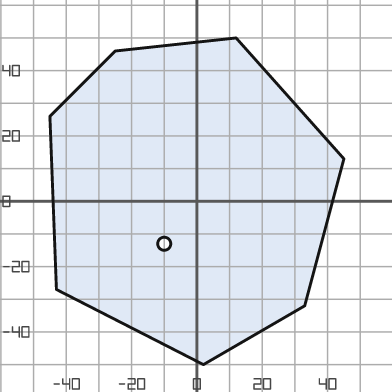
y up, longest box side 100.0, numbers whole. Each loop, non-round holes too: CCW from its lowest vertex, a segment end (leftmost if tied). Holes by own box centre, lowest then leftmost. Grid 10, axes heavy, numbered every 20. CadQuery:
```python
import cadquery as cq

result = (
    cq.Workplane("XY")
    .moveTo(2.0, -50.0)
    .lineTo(33.0, -32.0)
    .lineTo(45.0, 13.0)
    .lineTo(12.0, 50.0)
    .lineTo(-25.0, 46.0)
    .lineTo(-45.0, 26.0)
    .lineTo(-43.0, -27.0)
    .close()
    .moveTo(-10.0, -13.0)
    .circle(2.0)
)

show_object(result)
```